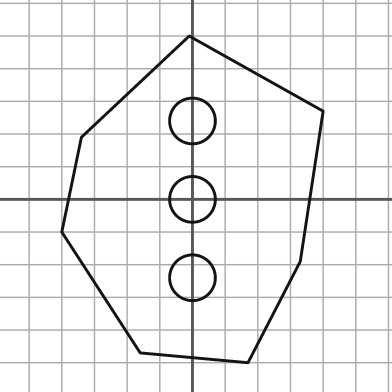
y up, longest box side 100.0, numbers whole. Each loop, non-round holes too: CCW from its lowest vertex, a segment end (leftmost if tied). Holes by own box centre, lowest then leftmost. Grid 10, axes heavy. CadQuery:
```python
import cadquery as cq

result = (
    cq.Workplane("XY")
    .moveTo(17.0, -50.0)
    .lineTo(33.0, -19.0)
    .lineTo(40.0, 27.0)
    .lineTo(-1.0, 50.0)
    .lineTo(-34.0, 19.0)
    .lineTo(-40.0, -10.0)
    .lineTo(-16.0, -47.0)
    .close()
    .moveTo(0.0, -24.0)
    .circle(7.0)
    .moveTo(0.0, 0.0)
    .circle(7.0)
    .moveTo(0.0, 24.0)
    .circle(7.0)
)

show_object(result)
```